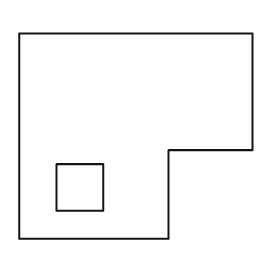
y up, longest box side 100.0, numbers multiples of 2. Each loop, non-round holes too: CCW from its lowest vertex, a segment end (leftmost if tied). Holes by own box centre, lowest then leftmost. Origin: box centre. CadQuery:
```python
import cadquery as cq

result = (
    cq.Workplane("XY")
    .moveTo(-50.0, -44.0)
    .lineTo(14.0, -44.0)
    .lineTo(14.0, -6.0)
    .lineTo(50.0, -6.0)
    .lineTo(50.0, 44.0)
    .lineTo(-50.0, 44.0)
    .close()
    .moveTo(-34.0, -32.0)
    .lineTo(-14.0, -32.0)
    .lineTo(-14.0, -12.0)
    .lineTo(-34.0, -12.0)
    .close()
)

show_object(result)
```